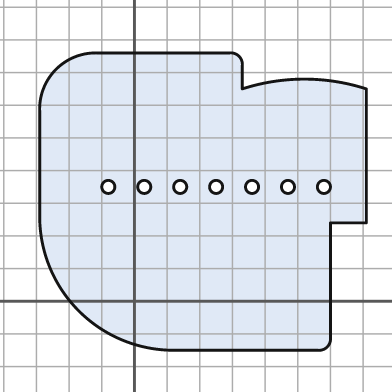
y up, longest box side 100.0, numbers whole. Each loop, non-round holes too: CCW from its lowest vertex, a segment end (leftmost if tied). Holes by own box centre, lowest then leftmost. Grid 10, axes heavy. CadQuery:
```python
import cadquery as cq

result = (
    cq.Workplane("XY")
    .moveTo(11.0, -15.0)
    .lineTo(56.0, -15.0)
    .threePointArc((59.0, -14.0), (60.0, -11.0))
    .lineTo(60.0, 24.0)
    .lineTo(71.0, 24.0)
    .lineTo(71.0, 65.0)
    .threePointArc((52.0, 68.0), (33.0, 65.0))
    .lineTo(33.0, 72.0)
    .threePointArc((32.0, 75.0), (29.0, 76.0))
    .lineTo(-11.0, 76.0)
    .threePointArc((-24.0, 71.0), (-29.0, 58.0))
    .lineTo(-29.0, 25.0)
    .threePointArc((-17.0, -3.0), (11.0, -15.0))
    .close()
    .moveTo(-8.0, 35.0)
    .circle(2.0)
    .moveTo(3.0, 35.0)
    .circle(2.0)
    .moveTo(14.0, 35.0)
    .circle(2.0)
    .moveTo(25.0, 35.0)
    .circle(2.0)
    .moveTo(36.0, 35.0)
    .circle(2.0)
    .moveTo(47.0, 35.0)
    .circle(2.0)
    .moveTo(58.0, 35.0)
    .circle(2.0)
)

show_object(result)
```